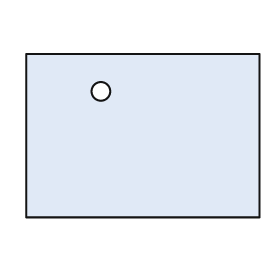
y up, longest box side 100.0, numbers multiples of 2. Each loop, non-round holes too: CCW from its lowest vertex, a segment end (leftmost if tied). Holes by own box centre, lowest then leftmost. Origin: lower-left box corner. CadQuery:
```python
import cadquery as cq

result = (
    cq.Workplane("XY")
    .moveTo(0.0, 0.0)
    .lineTo(100.0, 0.0)
    .lineTo(100.0, 70.0)
    .lineTo(0.0, 70.0)
    .close()
    .moveTo(32.0, 54.0)
    .circle(4.0)
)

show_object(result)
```